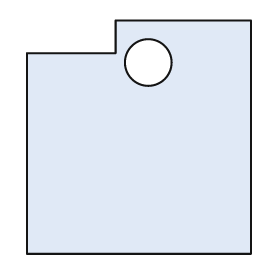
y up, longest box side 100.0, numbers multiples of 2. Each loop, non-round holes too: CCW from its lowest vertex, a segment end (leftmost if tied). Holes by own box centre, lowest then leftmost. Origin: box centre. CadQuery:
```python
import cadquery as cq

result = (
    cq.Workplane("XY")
    .moveTo(-48.0, -50.0)
    .lineTo(48.0, -50.0)
    .lineTo(48.0, 50.0)
    .lineTo(-10.0, 50.0)
    .lineTo(-10.0, 36.0)
    .lineTo(-48.0, 36.0)
    .close()
    .moveTo(4.0, 32.0)
    .circle(10.0)
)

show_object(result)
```